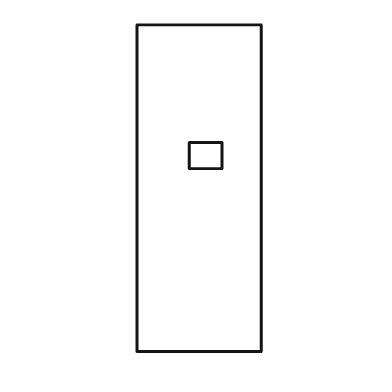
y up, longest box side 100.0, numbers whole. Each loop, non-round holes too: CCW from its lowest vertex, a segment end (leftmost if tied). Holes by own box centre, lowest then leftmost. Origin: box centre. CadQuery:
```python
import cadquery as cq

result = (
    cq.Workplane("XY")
    .moveTo(-19.0, -50.0)
    .lineTo(19.0, -50.0)
    .lineTo(19.0, 50.0)
    .lineTo(-19.0, 50.0)
    .close()
    .moveTo(-3.0, 6.0)
    .lineTo(7.0, 6.0)
    .lineTo(7.0, 14.0)
    .lineTo(-3.0, 14.0)
    .close()
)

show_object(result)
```